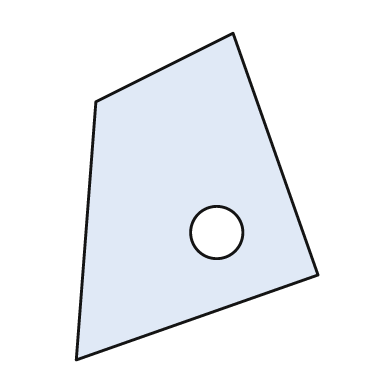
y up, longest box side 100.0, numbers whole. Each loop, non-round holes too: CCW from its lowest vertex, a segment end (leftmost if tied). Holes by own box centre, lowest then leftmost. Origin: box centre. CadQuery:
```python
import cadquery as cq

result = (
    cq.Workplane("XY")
    .moveTo(-37.0, -50.0)
    .lineTo(37.0, -24.0)
    .lineTo(11.0, 50.0)
    .lineTo(-31.0, 29.0)
    .close()
    .moveTo(6.0, -11.0)
    .circle(8.0)
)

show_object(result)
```